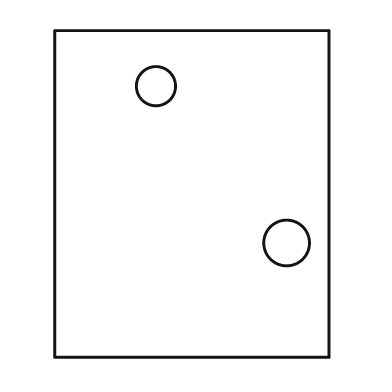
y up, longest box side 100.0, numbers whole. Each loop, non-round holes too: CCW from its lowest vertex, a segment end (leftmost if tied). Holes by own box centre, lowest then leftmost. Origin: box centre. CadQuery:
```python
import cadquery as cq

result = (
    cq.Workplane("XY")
    .moveTo(-42.0, -50.0)
    .lineTo(42.0, -50.0)
    .lineTo(42.0, 50.0)
    .lineTo(-42.0, 50.0)
    .close()
    .moveTo(29.0, -15.0)
    .circle(7.0)
    .moveTo(-11.0, 33.0)
    .circle(6.0)
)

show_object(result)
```